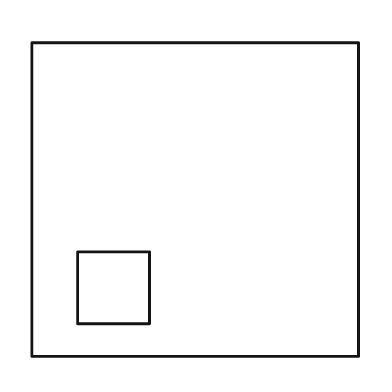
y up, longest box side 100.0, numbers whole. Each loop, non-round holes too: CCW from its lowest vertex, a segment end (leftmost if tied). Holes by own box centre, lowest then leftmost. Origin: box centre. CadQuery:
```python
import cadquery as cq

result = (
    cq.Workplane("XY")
    .moveTo(-50.0, -48.0)
    .lineTo(50.0, -48.0)
    .lineTo(50.0, 48.0)
    .lineTo(-50.0, 48.0)
    .close()
    .moveTo(-36.0, -38.0)
    .lineTo(-14.0, -38.0)
    .lineTo(-14.0, -16.0)
    .lineTo(-36.0, -16.0)
    .close()
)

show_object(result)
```